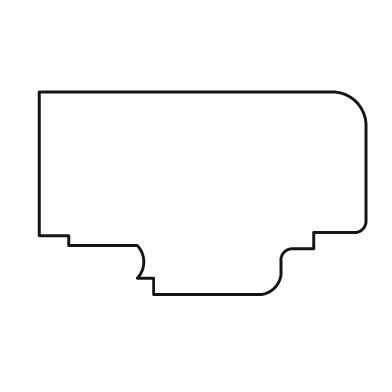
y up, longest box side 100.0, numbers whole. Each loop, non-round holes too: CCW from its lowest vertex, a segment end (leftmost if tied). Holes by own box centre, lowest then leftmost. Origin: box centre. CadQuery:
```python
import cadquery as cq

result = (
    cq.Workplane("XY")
    .moveTo(-15.0, -31.0)
    .lineTo(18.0, -31.0)
    .threePointArc((22.0, -29.0), (24.0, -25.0))
    .lineTo(24.0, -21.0)
    .threePointArc((25.0, -18.0), (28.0, -17.0))
    .lineTo(34.0, -17.0)
    .lineTo(34.0, -12.0)
    .lineTo(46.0, -12.0)
    .threePointArc((49.0, -11.0), (50.0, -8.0))
    .lineTo(50.0, 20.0)
    .threePointArc((47.0, 28.0), (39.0, 31.0))
    .lineTo(-50.0, 31.0)
    .lineTo(-50.0, -13.0)
    .lineTo(-41.0, -13.0)
    .lineTo(-41.0, -16.0)
    .lineTo(-20.0, -16.0)
    .threePointArc((-18.0, -21.0), (-20.0, -26.0))
    .lineTo(-15.0, -26.0)
    .close()
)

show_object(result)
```